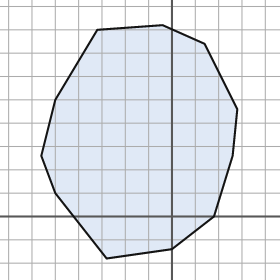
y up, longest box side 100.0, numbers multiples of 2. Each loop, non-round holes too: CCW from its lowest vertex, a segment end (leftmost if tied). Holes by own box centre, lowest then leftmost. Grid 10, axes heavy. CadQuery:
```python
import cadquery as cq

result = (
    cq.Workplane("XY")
    .moveTo(-28.0, -18.0)
    .lineTo(0.0, -14.0)
    .lineTo(18.0, 0.0)
    .lineTo(26.0, 26.0)
    .lineTo(28.0, 46.0)
    .lineTo(14.0, 74.0)
    .lineTo(-4.0, 82.0)
    .lineTo(-32.0, 80.0)
    .lineTo(-50.0, 50.0)
    .lineTo(-56.0, 26.0)
    .lineTo(-50.0, 10.0)
    .close()
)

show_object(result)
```